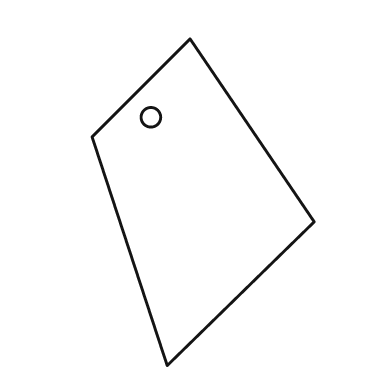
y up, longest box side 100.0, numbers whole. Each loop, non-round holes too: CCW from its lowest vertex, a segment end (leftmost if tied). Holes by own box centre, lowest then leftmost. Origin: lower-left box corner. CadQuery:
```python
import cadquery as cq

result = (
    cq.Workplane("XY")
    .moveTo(23.0, 0.0)
    .lineTo(68.0, 44.0)
    .lineTo(30.0, 100.0)
    .lineTo(0.0, 70.0)
    .close()
    .moveTo(18.0, 76.0)
    .circle(3.0)
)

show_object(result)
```